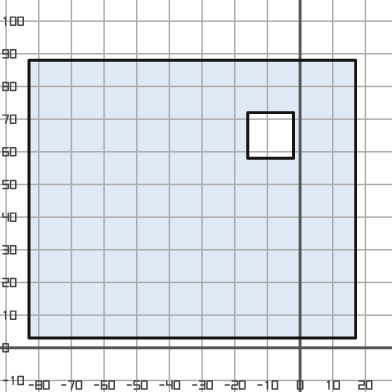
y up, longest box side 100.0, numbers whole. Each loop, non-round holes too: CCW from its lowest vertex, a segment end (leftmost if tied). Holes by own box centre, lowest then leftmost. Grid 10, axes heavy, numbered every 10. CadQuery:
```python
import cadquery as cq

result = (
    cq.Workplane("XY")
    .moveTo(-83.0, 3.0)
    .lineTo(17.0, 3.0)
    .lineTo(17.0, 88.0)
    .lineTo(-83.0, 88.0)
    .close()
    .moveTo(-16.0, 58.0)
    .lineTo(-2.0, 58.0)
    .lineTo(-2.0, 72.0)
    .lineTo(-16.0, 72.0)
    .close()
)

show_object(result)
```